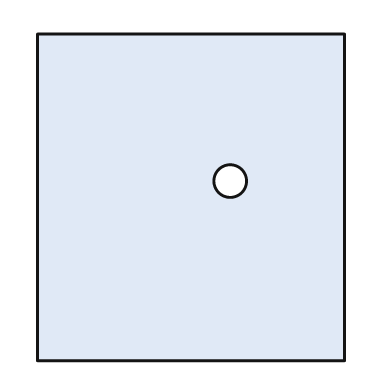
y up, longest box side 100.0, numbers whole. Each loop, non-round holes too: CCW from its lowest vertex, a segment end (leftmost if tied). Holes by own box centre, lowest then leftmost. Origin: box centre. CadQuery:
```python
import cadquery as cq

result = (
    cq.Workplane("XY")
    .moveTo(-47.0, -50.0)
    .lineTo(47.0, -50.0)
    .lineTo(47.0, 50.0)
    .lineTo(-47.0, 50.0)
    .close()
    .moveTo(12.0, 5.0)
    .circle(5.0)
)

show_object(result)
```